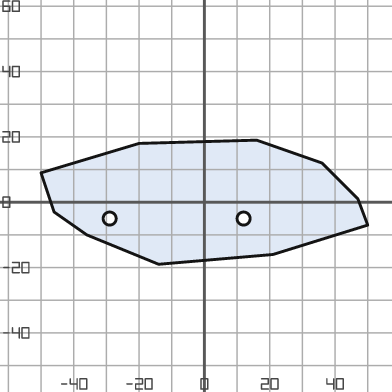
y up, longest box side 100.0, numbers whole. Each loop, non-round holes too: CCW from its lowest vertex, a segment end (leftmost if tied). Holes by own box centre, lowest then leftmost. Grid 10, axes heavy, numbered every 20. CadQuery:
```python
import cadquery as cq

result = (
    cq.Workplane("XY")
    .moveTo(-14.0, -19.0)
    .lineTo(21.0, -16.0)
    .lineTo(50.0, -7.0)
    .lineTo(47.0, 1.0)
    .lineTo(36.0, 12.0)
    .lineTo(16.0, 19.0)
    .lineTo(-20.0, 18.0)
    .lineTo(-50.0, 9.0)
    .lineTo(-46.0, -3.0)
    .lineTo(-36.0, -10.0)
    .close()
    .moveTo(-29.0, -5.0)
    .circle(2.0)
    .moveTo(12.0, -5.0)
    .circle(2.0)
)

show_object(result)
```